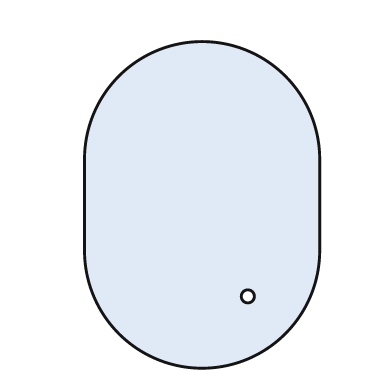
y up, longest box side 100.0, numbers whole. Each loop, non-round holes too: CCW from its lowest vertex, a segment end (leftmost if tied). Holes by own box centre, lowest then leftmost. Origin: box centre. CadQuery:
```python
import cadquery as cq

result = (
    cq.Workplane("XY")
    .moveTo(-36.0, -14.0)
    .threePointArc((0.0, -50.0), (36.0, -14.0))
    .lineTo(36.0, 14.0)
    .threePointArc((0.0, 50.0), (-36.0, 14.0))
    .close()
    .moveTo(14.0, -28.0)
    .circle(2.0)
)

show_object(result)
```